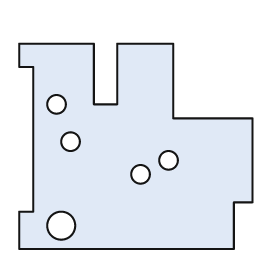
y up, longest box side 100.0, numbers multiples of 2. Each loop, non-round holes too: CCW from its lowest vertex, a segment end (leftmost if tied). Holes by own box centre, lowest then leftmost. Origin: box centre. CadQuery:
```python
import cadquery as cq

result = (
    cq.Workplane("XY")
    .moveTo(-50.0, -44.0)
    .lineTo(42.0, -44.0)
    .lineTo(42.0, -24.0)
    .lineTo(50.0, -24.0)
    .lineTo(50.0, 12.0)
    .lineTo(16.0, 12.0)
    .lineTo(16.0, 44.0)
    .lineTo(-8.0, 44.0)
    .lineTo(-8.0, 18.0)
    .lineTo(-18.0, 18.0)
    .lineTo(-18.0, 44.0)
    .lineTo(-50.0, 44.0)
    .lineTo(-50.0, 34.0)
    .lineTo(-44.0, 34.0)
    .lineTo(-44.0, -28.0)
    .lineTo(-50.0, -28.0)
    .close()
    .moveTo(-32.0, -34.0)
    .circle(6.0)
    .moveTo(2.0, -12.0)
    .circle(4.0)
    .moveTo(14.0, -6.0)
    .circle(4.0)
    .moveTo(-28.0, 2.0)
    .circle(4.0)
    .moveTo(-34.0, 18.0)
    .circle(4.0)
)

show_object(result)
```